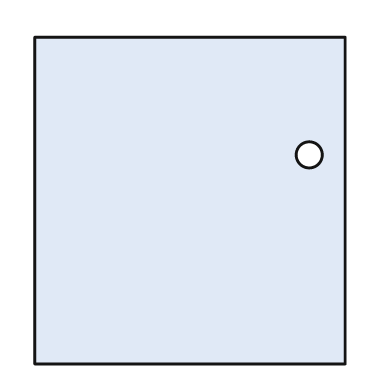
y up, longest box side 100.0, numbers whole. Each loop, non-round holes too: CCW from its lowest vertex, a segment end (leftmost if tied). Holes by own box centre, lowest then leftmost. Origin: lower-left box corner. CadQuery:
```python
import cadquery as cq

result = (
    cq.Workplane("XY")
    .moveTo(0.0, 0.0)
    .lineTo(95.0, 0.0)
    .lineTo(95.0, 100.0)
    .lineTo(0.0, 100.0)
    .close()
    .moveTo(84.0, 64.0)
    .circle(4.0)
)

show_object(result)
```